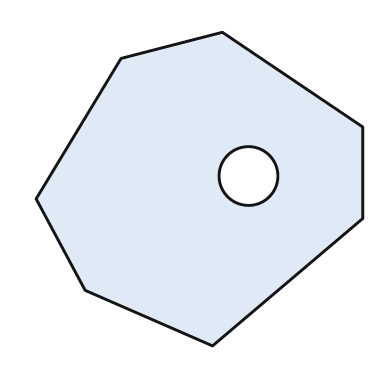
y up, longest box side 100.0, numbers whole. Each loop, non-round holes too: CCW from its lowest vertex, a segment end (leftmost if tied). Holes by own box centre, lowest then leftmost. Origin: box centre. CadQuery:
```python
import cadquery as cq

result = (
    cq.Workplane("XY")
    .moveTo(4.0, -48.0)
    .lineTo(50.0, -9.0)
    .lineTo(50.0, 19.0)
    .lineTo(7.0, 48.0)
    .lineTo(-24.0, 40.0)
    .lineTo(-50.0, -3.0)
    .lineTo(-35.0, -31.0)
    .close()
    .moveTo(15.0, 4.0)
    .circle(9.0)
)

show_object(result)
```